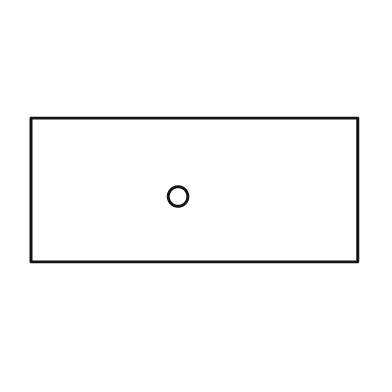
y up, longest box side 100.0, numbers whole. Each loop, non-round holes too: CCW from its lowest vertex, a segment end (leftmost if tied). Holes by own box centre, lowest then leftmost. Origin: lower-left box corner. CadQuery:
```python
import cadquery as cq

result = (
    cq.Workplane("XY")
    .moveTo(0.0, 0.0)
    .lineTo(100.0, 0.0)
    .lineTo(100.0, 44.0)
    .lineTo(0.0, 44.0)
    .close()
    .moveTo(45.0, 20.0)
    .circle(3.0)
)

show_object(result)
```